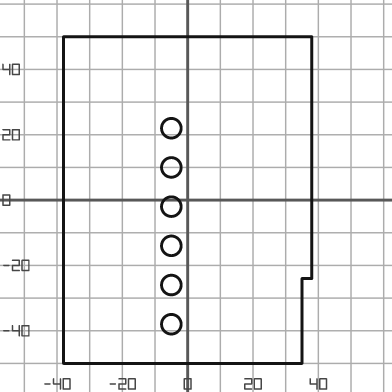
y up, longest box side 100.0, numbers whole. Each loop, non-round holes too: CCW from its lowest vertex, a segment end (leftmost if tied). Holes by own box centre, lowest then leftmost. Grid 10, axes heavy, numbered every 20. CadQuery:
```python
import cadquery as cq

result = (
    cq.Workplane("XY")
    .moveTo(-38.0, -50.0)
    .lineTo(35.0, -50.0)
    .lineTo(35.0, -24.0)
    .lineTo(38.0, -24.0)
    .lineTo(38.0, 50.0)
    .lineTo(-38.0, 50.0)
    .close()
    .moveTo(-5.0, -38.0)
    .circle(3.0)
    .moveTo(-5.0, -26.0)
    .circle(3.0)
    .moveTo(-5.0, -14.0)
    .circle(3.0)
    .moveTo(-5.0, -2.0)
    .circle(3.0)
    .moveTo(-5.0, 10.0)
    .circle(3.0)
    .moveTo(-5.0, 22.0)
    .circle(3.0)
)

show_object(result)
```